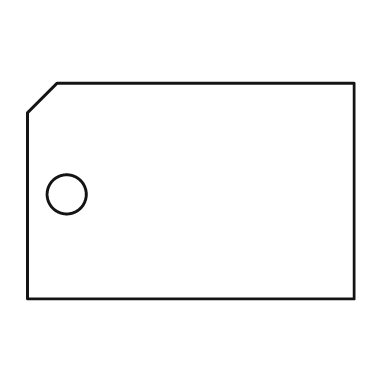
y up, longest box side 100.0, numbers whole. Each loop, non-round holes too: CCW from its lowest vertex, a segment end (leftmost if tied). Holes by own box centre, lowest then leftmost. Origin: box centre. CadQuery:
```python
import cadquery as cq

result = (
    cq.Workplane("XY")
    .moveTo(-50.0, -33.0)
    .lineTo(50.0, -33.0)
    .lineTo(50.0, 33.0)
    .lineTo(-41.0, 33.0)
    .lineTo(-50.0, 24.0)
    .close()
    .moveTo(-38.0, -1.0)
    .circle(6.0)
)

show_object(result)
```